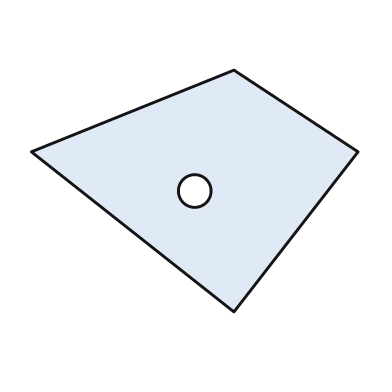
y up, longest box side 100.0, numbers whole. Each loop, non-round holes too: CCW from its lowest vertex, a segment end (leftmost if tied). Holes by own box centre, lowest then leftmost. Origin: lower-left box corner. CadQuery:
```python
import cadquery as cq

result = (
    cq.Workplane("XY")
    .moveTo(62.0, 0.0)
    .lineTo(100.0, 49.0)
    .lineTo(62.0, 74.0)
    .lineTo(0.0, 49.0)
    .close()
    .moveTo(50.0, 37.0)
    .circle(5.0)
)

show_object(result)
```